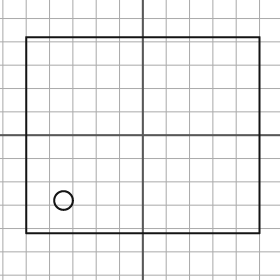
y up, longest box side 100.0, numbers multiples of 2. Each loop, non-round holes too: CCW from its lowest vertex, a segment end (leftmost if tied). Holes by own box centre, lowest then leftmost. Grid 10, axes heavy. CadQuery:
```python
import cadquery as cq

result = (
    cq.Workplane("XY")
    .moveTo(-50.0, -42.0)
    .lineTo(50.0, -42.0)
    .lineTo(50.0, 42.0)
    .lineTo(-50.0, 42.0)
    .close()
    .moveTo(-34.0, -28.0)
    .circle(4.0)
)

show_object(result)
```